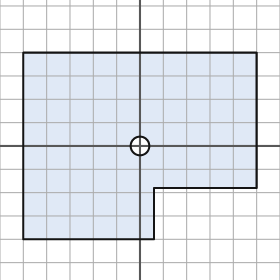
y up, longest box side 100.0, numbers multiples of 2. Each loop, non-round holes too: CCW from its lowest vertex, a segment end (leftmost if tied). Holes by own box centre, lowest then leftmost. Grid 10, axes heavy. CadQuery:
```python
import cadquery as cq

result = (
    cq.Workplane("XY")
    .moveTo(-50.0, -40.0)
    .lineTo(6.0, -40.0)
    .lineTo(6.0, -18.0)
    .lineTo(50.0, -18.0)
    .lineTo(50.0, 40.0)
    .lineTo(-50.0, 40.0)
    .close()
    .moveTo(0.0, 0.0)
    .circle(4.0)
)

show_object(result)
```